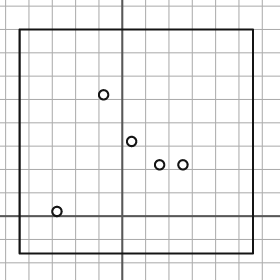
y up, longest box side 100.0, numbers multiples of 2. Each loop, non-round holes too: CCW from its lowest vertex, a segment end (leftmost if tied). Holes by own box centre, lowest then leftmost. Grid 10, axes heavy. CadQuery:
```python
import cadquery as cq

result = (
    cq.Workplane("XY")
    .moveTo(-44.0, -16.0)
    .lineTo(56.0, -16.0)
    .lineTo(56.0, 80.0)
    .lineTo(-44.0, 80.0)
    .close()
    .moveTo(-28.0, 2.0)
    .circle(2.0)
    .moveTo(16.0, 22.0)
    .circle(2.0)
    .moveTo(26.0, 22.0)
    .circle(2.0)
    .moveTo(4.0, 32.0)
    .circle(2.0)
    .moveTo(-8.0, 52.0)
    .circle(2.0)
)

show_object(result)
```